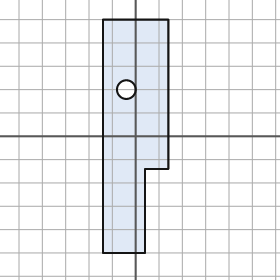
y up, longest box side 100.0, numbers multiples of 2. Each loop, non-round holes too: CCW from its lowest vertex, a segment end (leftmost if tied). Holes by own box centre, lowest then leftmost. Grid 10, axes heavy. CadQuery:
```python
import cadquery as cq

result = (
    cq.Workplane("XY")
    .moveTo(-14.0, -50.0)
    .lineTo(4.0, -50.0)
    .lineTo(4.0, -14.0)
    .lineTo(14.0, -14.0)
    .lineTo(14.0, 50.0)
    .lineTo(-14.0, 50.0)
    .close()
    .moveTo(-4.0, 20.0)
    .circle(4.0)
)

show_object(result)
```